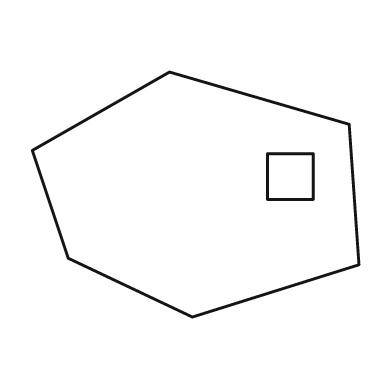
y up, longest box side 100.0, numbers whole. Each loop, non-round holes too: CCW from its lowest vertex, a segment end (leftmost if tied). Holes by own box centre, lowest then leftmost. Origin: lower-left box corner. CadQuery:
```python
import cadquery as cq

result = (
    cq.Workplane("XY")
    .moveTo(49.0, 0.0)
    .lineTo(100.0, 16.0)
    .lineTo(97.0, 59.0)
    .lineTo(42.0, 75.0)
    .lineTo(0.0, 51.0)
    .lineTo(11.0, 18.0)
    .close()
    .moveTo(72.0, 36.0)
    .lineTo(86.0, 36.0)
    .lineTo(86.0, 50.0)
    .lineTo(72.0, 50.0)
    .close()
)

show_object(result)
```